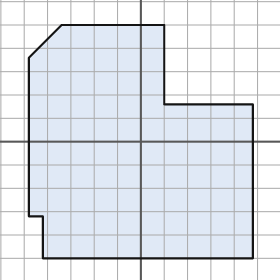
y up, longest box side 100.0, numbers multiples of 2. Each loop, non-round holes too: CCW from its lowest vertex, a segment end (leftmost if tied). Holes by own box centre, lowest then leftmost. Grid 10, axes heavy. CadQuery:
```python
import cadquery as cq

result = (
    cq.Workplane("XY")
    .moveTo(-42.0, -50.0)
    .lineTo(48.0, -50.0)
    .lineTo(48.0, 16.0)
    .lineTo(10.0, 16.0)
    .lineTo(10.0, 50.0)
    .lineTo(-34.0, 50.0)
    .lineTo(-48.0, 36.0)
    .lineTo(-48.0, -32.0)
    .lineTo(-42.0, -32.0)
    .close()
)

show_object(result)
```